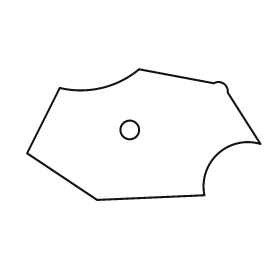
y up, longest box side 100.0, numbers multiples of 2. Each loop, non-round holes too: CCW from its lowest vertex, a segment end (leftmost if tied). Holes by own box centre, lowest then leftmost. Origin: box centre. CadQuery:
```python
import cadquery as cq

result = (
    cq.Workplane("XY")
    .moveTo(-20.0, -28.0)
    .lineTo(26.0, -26.0)
    .threePointArc((32.0, -8.0), (50.0, -4.0))
    .lineTo(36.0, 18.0)
    .threePointArc((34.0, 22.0), (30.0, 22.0))
    .lineTo(-2.0, 28.0)
    .threePointArc((-18.0, 20.0), (-36.0, 20.0))
    .lineTo(-50.0, -8.0)
    .close()
    .moveTo(-6.0, 2.0)
    .circle(4.0)
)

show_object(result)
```